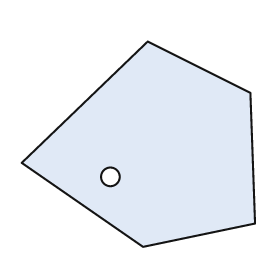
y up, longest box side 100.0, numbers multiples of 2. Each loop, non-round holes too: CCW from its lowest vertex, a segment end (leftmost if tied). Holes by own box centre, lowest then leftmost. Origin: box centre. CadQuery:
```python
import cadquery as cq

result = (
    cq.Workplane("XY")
    .moveTo(2.0, -44.0)
    .lineTo(50.0, -34.0)
    .lineTo(48.0, 22.0)
    .lineTo(4.0, 44.0)
    .lineTo(-50.0, -8.0)
    .close()
    .moveTo(-12.0, -14.0)
    .circle(4.0)
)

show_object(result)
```